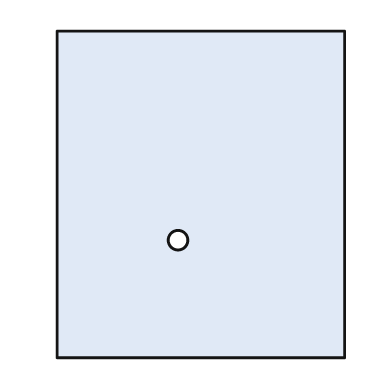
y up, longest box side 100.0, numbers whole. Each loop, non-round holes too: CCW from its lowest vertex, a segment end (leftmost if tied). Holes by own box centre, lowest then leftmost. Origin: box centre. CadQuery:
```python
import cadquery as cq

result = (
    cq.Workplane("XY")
    .moveTo(-44.0, -50.0)
    .lineTo(44.0, -50.0)
    .lineTo(44.0, 50.0)
    .lineTo(-44.0, 50.0)
    .close()
    .moveTo(-7.0, -14.0)
    .circle(3.0)
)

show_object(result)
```